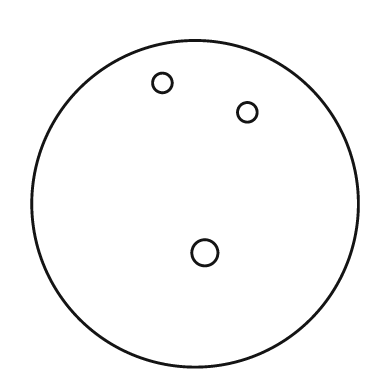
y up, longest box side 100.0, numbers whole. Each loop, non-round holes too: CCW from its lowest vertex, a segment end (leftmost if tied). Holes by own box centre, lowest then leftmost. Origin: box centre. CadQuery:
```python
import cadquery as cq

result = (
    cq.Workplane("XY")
    .moveTo(0.0, 0.0)
    .circle(50.0)
    .moveTo(3.0, -15.0)
    .circle(4.0)
    .moveTo(16.0, 28.0)
    .circle(3.0)
    .moveTo(-10.0, 37.0)
    .circle(3.0)
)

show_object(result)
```